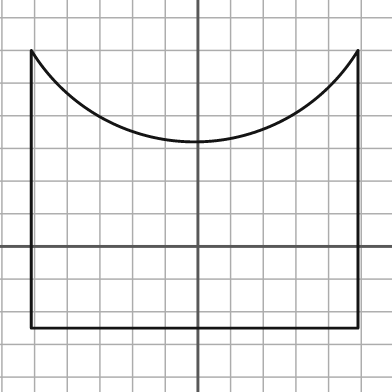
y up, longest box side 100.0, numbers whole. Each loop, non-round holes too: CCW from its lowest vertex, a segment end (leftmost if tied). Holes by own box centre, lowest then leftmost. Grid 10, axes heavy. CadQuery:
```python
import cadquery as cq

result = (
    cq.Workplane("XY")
    .moveTo(-51.0, -25.0)
    .lineTo(49.0, -25.0)
    .lineTo(49.0, 60.0)
    .threePointArc((-1.0, 32.0), (-51.0, 60.0))
    .close()
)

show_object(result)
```